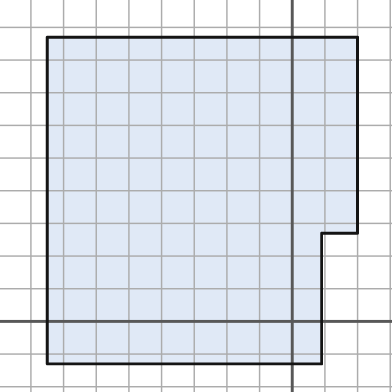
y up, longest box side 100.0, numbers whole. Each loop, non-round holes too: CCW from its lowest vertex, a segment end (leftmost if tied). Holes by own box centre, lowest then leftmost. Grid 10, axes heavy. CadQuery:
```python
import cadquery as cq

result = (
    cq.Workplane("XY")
    .moveTo(-75.0, -13.0)
    .lineTo(9.0, -13.0)
    .lineTo(9.0, 27.0)
    .lineTo(20.0, 27.0)
    .lineTo(20.0, 87.0)
    .lineTo(-75.0, 87.0)
    .close()
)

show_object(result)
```